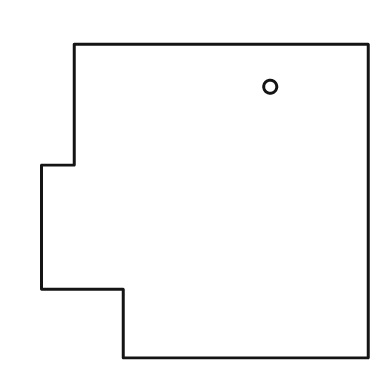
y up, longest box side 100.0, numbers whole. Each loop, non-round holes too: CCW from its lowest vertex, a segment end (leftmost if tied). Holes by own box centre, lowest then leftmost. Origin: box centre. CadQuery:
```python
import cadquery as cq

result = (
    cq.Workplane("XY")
    .moveTo(-25.0, -48.0)
    .lineTo(50.0, -48.0)
    .lineTo(50.0, 48.0)
    .lineTo(-40.0, 48.0)
    .lineTo(-40.0, 11.0)
    .lineTo(-50.0, 11.0)
    .lineTo(-50.0, -27.0)
    .lineTo(-25.0, -27.0)
    .close()
    .moveTo(20.0, 35.0)
    .circle(2.0)
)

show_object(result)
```